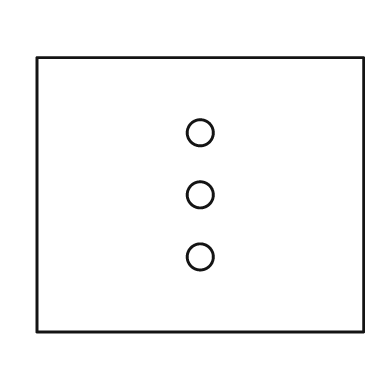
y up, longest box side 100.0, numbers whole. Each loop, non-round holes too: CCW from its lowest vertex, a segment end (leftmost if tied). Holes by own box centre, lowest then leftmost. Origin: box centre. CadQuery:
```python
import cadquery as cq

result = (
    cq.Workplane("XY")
    .moveTo(-50.0, -42.0)
    .lineTo(50.0, -42.0)
    .lineTo(50.0, 42.0)
    .lineTo(-50.0, 42.0)
    .close()
    .moveTo(0.0, -19.0)
    .circle(4.0)
    .moveTo(0.0, 0.0)
    .circle(4.0)
    .moveTo(0.0, 19.0)
    .circle(4.0)
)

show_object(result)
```